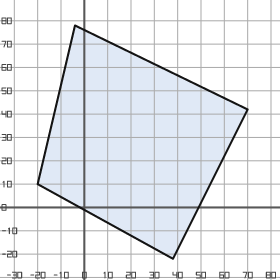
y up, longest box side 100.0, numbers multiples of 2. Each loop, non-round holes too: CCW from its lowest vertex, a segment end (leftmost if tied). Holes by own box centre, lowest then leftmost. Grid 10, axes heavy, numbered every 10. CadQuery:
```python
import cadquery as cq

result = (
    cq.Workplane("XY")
    .moveTo(38.0, -22.0)
    .lineTo(70.0, 42.0)
    .lineTo(-4.0, 78.0)
    .lineTo(-20.0, 10.0)
    .close()
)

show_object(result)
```